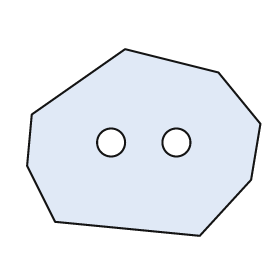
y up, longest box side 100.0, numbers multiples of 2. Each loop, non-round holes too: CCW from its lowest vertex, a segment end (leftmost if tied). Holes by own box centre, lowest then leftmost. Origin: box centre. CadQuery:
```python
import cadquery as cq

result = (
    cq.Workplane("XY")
    .moveTo(24.0, -40.0)
    .lineTo(46.0, -16.0)
    .lineTo(50.0, 8.0)
    .lineTo(32.0, 30.0)
    .lineTo(-8.0, 40.0)
    .lineTo(-48.0, 12.0)
    .lineTo(-50.0, -10.0)
    .lineTo(-38.0, -34.0)
    .close()
    .moveTo(-14.0, 0.0)
    .circle(6.0)
    .moveTo(14.0, 0.0)
    .circle(6.0)
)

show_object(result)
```